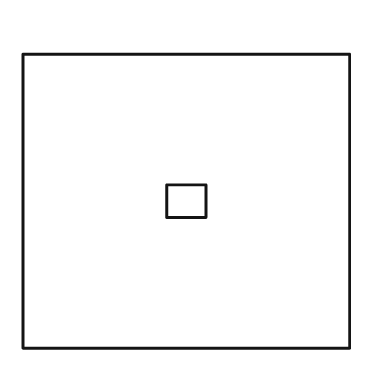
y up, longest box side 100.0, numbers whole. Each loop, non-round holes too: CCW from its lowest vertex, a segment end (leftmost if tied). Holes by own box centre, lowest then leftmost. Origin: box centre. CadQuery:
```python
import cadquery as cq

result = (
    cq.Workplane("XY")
    .moveTo(-50.0, -45.0)
    .lineTo(50.0, -45.0)
    .lineTo(50.0, 45.0)
    .lineTo(-50.0, 45.0)
    .close()
    .moveTo(-6.0, -5.0)
    .lineTo(6.0, -5.0)
    .lineTo(6.0, 5.0)
    .lineTo(-6.0, 5.0)
    .close()
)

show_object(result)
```